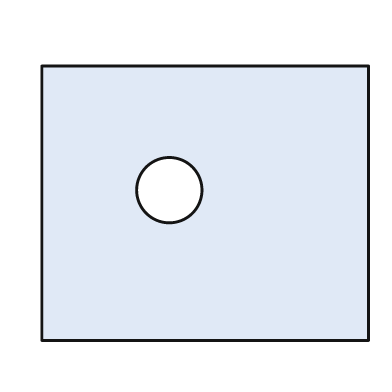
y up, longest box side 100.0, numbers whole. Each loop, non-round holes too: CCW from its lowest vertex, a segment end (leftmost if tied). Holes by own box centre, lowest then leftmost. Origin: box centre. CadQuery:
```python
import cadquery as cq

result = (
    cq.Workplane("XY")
    .moveTo(-50.0, -42.0)
    .lineTo(50.0, -42.0)
    .lineTo(50.0, 42.0)
    .lineTo(-50.0, 42.0)
    .close()
    .moveTo(-11.0, 4.0)
    .circle(10.0)
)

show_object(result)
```